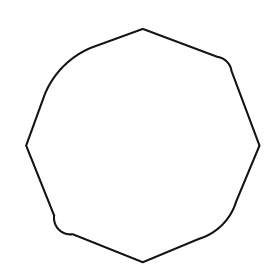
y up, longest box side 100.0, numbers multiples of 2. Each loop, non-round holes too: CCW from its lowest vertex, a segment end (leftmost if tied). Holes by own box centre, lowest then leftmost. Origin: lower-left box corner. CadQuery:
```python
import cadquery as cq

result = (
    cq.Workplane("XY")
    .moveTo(50.0, 0.0)
    .lineTo(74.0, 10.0)
    .threePointArc((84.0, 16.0), (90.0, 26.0))
    .lineTo(100.0, 50.0)
    .lineTo(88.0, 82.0)
    .threePointArc((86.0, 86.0), (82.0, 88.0))
    .lineTo(50.0, 100.0)
    .lineTo(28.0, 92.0)
    .threePointArc((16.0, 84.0), (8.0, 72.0))
    .lineTo(0.0, 50.0)
    .lineTo(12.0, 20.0)
    .threePointArc((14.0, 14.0), (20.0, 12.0))
    .close()
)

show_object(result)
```